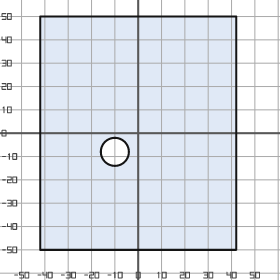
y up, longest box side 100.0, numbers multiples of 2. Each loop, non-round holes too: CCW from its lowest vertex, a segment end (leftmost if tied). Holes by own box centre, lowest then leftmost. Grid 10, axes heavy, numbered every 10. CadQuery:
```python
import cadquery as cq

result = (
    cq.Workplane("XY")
    .moveTo(-42.0, -50.0)
    .lineTo(42.0, -50.0)
    .lineTo(42.0, 50.0)
    .lineTo(-42.0, 50.0)
    .close()
    .moveTo(-10.0, -8.0)
    .circle(6.0)
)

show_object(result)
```